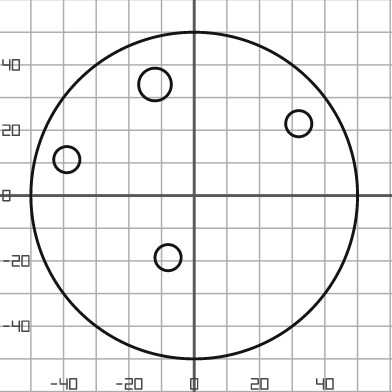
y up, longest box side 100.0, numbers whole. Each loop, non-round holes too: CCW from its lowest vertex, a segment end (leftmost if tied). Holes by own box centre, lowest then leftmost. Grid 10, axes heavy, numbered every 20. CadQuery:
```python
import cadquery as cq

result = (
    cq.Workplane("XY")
    .moveTo(0.0, 0.0)
    .circle(50.0)
    .moveTo(-8.0, -19.0)
    .circle(4.0)
    .moveTo(-39.0, 11.0)
    .circle(4.0)
    .moveTo(32.0, 22.0)
    .circle(4.0)
    .moveTo(-12.0, 34.0)
    .circle(5.0)
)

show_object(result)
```